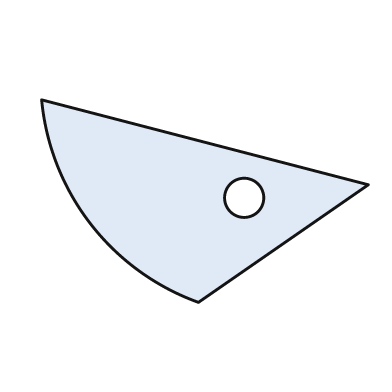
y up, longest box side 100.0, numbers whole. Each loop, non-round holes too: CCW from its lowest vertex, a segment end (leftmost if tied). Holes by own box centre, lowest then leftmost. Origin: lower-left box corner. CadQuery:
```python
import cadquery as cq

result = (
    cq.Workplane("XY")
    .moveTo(48.0, 0.0)
    .lineTo(100.0, 36.0)
    .lineTo(0.0, 62.0)
    .threePointArc((15.0, 24.0), (48.0, 0.0))
    .close()
    .moveTo(62.0, 32.0)
    .circle(6.0)
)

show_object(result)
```